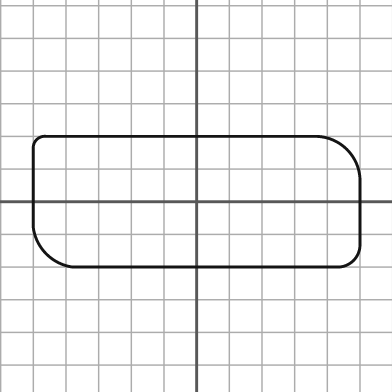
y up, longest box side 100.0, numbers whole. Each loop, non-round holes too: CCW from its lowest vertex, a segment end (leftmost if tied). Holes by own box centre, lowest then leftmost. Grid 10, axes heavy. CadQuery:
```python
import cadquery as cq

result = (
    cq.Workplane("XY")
    .moveTo(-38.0, -20.0)
    .lineTo(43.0, -20.0)
    .threePointArc((48.0, -18.0), (50.0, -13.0))
    .lineTo(50.0, 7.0)
    .threePointArc((46.0, 16.0), (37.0, 20.0))
    .lineTo(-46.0, 20.0)
    .threePointArc((-49.0, 19.0), (-50.0, 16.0))
    .lineTo(-50.0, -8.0)
    .threePointArc((-46.0, -16.0), (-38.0, -20.0))
    .close()
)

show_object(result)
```